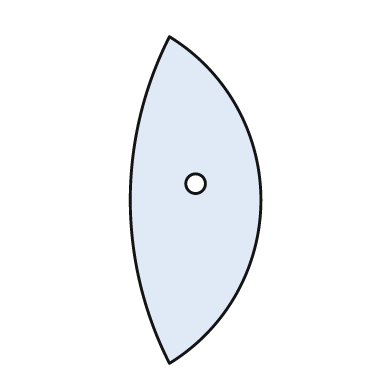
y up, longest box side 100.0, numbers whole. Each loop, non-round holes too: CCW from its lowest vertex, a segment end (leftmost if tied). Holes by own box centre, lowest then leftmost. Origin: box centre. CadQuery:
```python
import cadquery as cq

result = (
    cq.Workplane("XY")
    .moveTo(-8.0, -50.0)
    .threePointArc((20.0, 0.0), (-8.0, 50.0))
    .threePointArc((-20.0, 0.0), (-8.0, -50.0))
    .close()
    .moveTo(0.0, 5.0)
    .circle(3.0)
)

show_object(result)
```